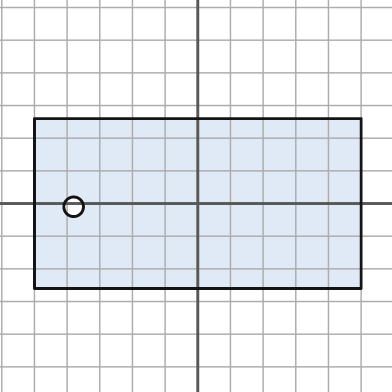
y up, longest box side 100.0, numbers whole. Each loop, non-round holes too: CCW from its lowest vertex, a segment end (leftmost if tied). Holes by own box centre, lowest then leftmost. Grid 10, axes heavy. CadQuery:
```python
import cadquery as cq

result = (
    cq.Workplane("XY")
    .moveTo(-50.0, -26.0)
    .lineTo(50.0, -26.0)
    .lineTo(50.0, 26.0)
    .lineTo(-50.0, 26.0)
    .close()
    .moveTo(-38.0, -1.0)
    .circle(3.0)
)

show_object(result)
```